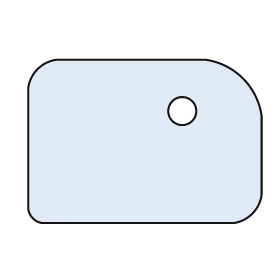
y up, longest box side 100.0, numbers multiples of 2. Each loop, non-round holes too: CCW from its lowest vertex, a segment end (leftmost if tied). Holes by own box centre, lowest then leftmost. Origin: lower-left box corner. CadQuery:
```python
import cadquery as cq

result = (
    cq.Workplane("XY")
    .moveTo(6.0, 0.0)
    .lineTo(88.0, 0.0)
    .threePointArc((96.0, 4.0), (100.0, 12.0))
    .lineTo(100.0, 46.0)
    .threePointArc((92.0, 62.0), (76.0, 70.0))
    .lineTo(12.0, 70.0)
    .threePointArc((4.0, 66.0), (0.0, 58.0))
    .lineTo(0.0, 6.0)
    .threePointArc((2.0, 2.0), (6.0, 0.0))
    .close()
    .moveTo(66.0, 48.0)
    .circle(6.0)
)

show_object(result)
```